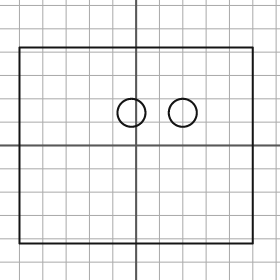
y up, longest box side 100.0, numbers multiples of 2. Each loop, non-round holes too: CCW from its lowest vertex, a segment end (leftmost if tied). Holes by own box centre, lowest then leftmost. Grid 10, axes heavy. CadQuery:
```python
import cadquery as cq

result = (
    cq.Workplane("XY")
    .moveTo(-50.0, -42.0)
    .lineTo(50.0, -42.0)
    .lineTo(50.0, 42.0)
    .lineTo(-50.0, 42.0)
    .close()
    .moveTo(-2.0, 14.0)
    .circle(6.0)
    .moveTo(20.0, 14.0)
    .circle(6.0)
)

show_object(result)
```